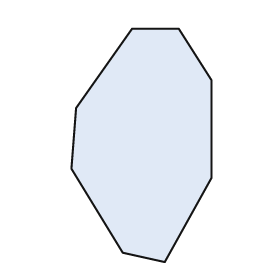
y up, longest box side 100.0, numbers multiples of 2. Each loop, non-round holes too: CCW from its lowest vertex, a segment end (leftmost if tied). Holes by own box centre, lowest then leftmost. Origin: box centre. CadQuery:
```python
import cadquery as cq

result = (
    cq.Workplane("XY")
    .moveTo(10.0, -50.0)
    .lineTo(30.0, -14.0)
    .lineTo(30.0, 28.0)
    .lineTo(16.0, 50.0)
    .lineTo(-4.0, 50.0)
    .lineTo(-28.0, 16.0)
    .lineTo(-30.0, -10.0)
    .lineTo(-8.0, -46.0)
    .close()
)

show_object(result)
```